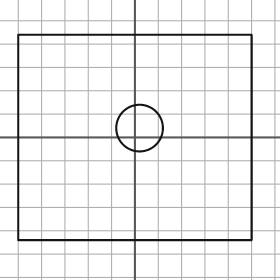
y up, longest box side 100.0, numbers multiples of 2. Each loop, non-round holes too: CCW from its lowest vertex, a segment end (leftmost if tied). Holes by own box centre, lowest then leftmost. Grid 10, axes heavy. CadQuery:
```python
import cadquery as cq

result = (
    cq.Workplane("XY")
    .moveTo(-50.0, -44.0)
    .lineTo(50.0, -44.0)
    .lineTo(50.0, 44.0)
    .lineTo(-50.0, 44.0)
    .close()
    .moveTo(2.0, 4.0)
    .circle(10.0)
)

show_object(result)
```